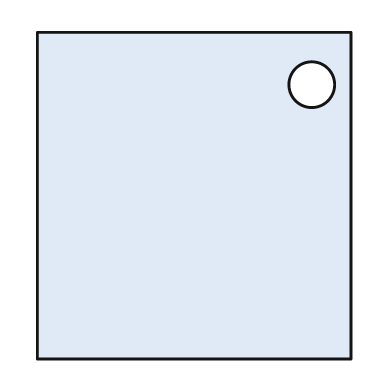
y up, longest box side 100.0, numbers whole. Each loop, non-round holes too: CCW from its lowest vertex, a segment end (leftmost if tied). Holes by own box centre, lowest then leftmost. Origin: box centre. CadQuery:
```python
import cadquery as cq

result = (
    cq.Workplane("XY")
    .moveTo(-48.0, -50.0)
    .lineTo(48.0, -50.0)
    .lineTo(48.0, 50.0)
    .lineTo(-48.0, 50.0)
    .close()
    .moveTo(36.0, 34.0)
    .circle(7.0)
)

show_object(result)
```